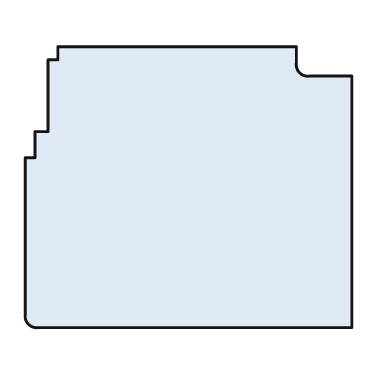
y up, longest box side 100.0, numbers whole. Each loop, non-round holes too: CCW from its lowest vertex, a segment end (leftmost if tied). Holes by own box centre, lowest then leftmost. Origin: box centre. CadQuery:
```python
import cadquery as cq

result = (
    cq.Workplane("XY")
    .moveTo(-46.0, -43.0)
    .lineTo(50.0, -43.0)
    .lineTo(50.0, 34.0)
    .lineTo(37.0, 34.0)
    .threePointArc((34.0, 35.0), (33.0, 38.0))
    .lineTo(33.0, 43.0)
    .lineTo(-40.0, 43.0)
    .lineTo(-40.0, 39.0)
    .lineTo(-43.0, 39.0)
    .lineTo(-43.0, 17.0)
    .lineTo(-47.0, 17.0)
    .lineTo(-47.0, 9.0)
    .lineTo(-50.0, 9.0)
    .lineTo(-50.0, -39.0)
    .threePointArc((-49.0, -42.0), (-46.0, -43.0))
    .close()
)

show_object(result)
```